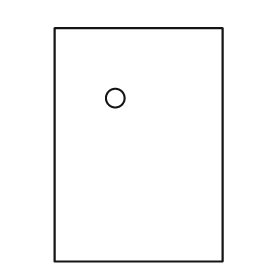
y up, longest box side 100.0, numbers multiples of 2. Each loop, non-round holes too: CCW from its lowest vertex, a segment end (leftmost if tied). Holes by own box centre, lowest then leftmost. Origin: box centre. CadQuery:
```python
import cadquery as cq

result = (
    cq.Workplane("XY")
    .moveTo(-36.0, -50.0)
    .lineTo(36.0, -50.0)
    .lineTo(36.0, 50.0)
    .lineTo(-36.0, 50.0)
    .close()
    .moveTo(-10.0, 20.0)
    .circle(4.0)
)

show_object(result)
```